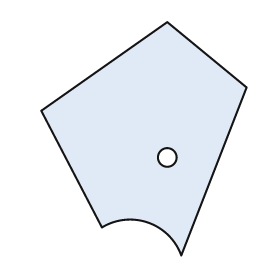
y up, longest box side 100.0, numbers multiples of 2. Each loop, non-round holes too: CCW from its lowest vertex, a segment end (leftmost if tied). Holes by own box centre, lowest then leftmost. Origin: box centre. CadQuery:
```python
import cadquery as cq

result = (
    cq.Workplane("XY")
    .moveTo(16.0, -50.0)
    .lineTo(44.0, 22.0)
    .lineTo(10.0, 50.0)
    .lineTo(-44.0, 12.0)
    .lineTo(-18.0, -38.0)
    .threePointArc((2.0, -36.0), (16.0, -50.0))
    .close()
    .moveTo(10.0, -8.0)
    .circle(4.0)
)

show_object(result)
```